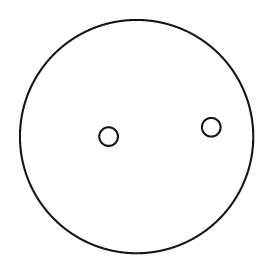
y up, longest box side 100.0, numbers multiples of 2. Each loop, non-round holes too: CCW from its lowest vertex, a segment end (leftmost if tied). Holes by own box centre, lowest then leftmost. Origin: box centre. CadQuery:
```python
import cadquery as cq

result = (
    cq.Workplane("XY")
    .moveTo(0.0, 0.0)
    .circle(50.0)
    .moveTo(-12.0, 0.0)
    .circle(4.0)
    .moveTo(32.0, 4.0)
    .circle(4.0)
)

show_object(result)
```